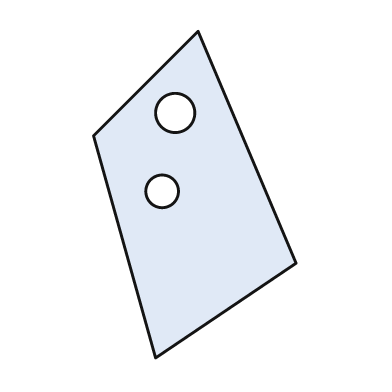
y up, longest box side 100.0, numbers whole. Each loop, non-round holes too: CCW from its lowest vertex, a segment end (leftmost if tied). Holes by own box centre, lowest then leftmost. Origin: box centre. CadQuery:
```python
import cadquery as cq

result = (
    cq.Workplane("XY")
    .moveTo(-12.0, -50.0)
    .lineTo(31.0, -21.0)
    .lineTo(1.0, 50.0)
    .lineTo(-31.0, 18.0)
    .close()
    .moveTo(-10.0, 1.0)
    .circle(5.0)
    .moveTo(-6.0, 25.0)
    .circle(6.0)
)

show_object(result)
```